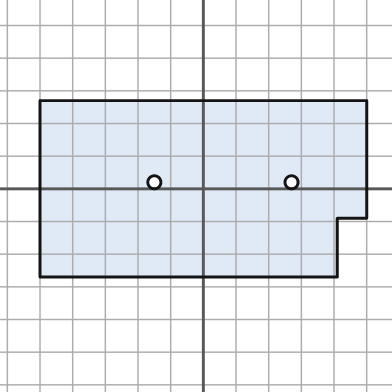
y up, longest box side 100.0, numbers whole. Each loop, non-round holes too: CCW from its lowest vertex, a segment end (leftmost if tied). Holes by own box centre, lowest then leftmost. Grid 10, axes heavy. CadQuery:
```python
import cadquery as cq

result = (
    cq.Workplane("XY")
    .moveTo(-50.0, -27.0)
    .lineTo(41.0, -27.0)
    .lineTo(41.0, -9.0)
    .lineTo(50.0, -9.0)
    .lineTo(50.0, 27.0)
    .lineTo(-50.0, 27.0)
    .close()
    .moveTo(-15.0, 2.0)
    .circle(2.0)
    .moveTo(27.0, 2.0)
    .circle(2.0)
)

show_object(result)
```